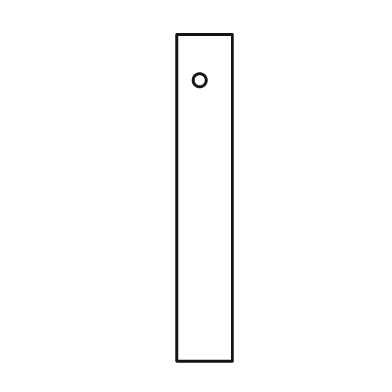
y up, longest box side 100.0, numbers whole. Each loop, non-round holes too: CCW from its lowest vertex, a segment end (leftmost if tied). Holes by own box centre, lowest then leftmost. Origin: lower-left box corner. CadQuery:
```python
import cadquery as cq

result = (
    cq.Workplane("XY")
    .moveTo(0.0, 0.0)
    .lineTo(17.0, 0.0)
    .lineTo(17.0, 100.0)
    .lineTo(0.0, 100.0)
    .close()
    .moveTo(7.0, 86.0)
    .circle(2.0)
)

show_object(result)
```